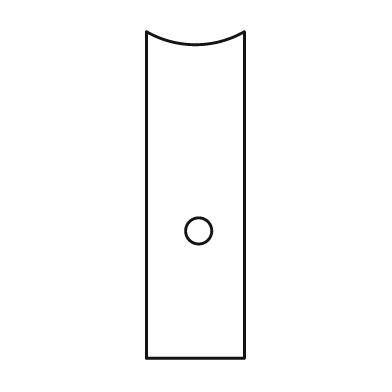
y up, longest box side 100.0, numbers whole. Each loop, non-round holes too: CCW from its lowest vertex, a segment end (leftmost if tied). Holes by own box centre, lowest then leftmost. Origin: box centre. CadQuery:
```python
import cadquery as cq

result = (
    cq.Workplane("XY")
    .moveTo(-15.0, -50.0)
    .lineTo(15.0, -50.0)
    .lineTo(15.0, 50.0)
    .threePointArc((0.0, 46.0), (-15.0, 50.0))
    .close()
    .moveTo(1.0, -11.0)
    .circle(4.0)
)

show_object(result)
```